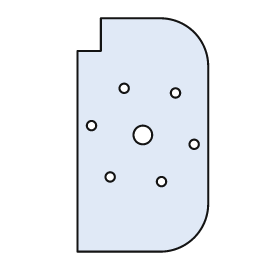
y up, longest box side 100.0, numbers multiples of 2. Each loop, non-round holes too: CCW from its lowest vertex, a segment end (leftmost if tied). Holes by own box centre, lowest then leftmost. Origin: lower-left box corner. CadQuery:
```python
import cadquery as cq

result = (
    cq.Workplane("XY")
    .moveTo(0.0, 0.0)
    .lineTo(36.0, 0.0)
    .threePointArc((50.0, 6.0), (56.0, 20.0))
    .lineTo(56.0, 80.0)
    .threePointArc((50.0, 94.0), (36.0, 100.0))
    .lineTo(10.0, 100.0)
    .lineTo(10.0, 86.0)
    .lineTo(0.0, 86.0)
    .close()
    .moveTo(36.0, 30.0)
    .circle(2.0)
    .moveTo(14.0, 32.0)
    .circle(2.0)
    .moveTo(50.0, 46.0)
    .circle(2.0)
    .moveTo(28.0, 50.0)
    .circle(4.0)
    .moveTo(6.0, 54.0)
    .circle(2.0)
    .moveTo(42.0, 68.0)
    .circle(2.0)
    .moveTo(20.0, 70.0)
    .circle(2.0)
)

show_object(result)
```